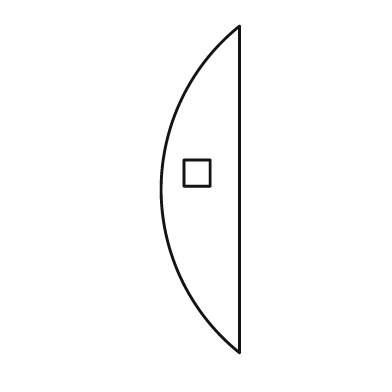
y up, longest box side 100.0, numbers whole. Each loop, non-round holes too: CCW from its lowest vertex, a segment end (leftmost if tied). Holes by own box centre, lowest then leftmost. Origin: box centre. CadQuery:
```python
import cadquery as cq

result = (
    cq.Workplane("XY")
    .moveTo(12.0, -50.0)
    .lineTo(12.0, 50.0)
    .threePointArc((-12.0, 0.0), (12.0, -50.0))
    .close()
    .moveTo(-5.0, 1.0)
    .lineTo(3.0, 1.0)
    .lineTo(3.0, 9.0)
    .lineTo(-5.0, 9.0)
    .close()
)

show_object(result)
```